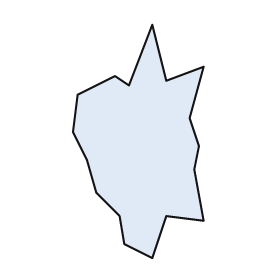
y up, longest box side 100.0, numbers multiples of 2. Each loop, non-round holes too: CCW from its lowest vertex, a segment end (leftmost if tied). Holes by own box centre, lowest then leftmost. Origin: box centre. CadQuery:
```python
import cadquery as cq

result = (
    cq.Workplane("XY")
    .moveTo(6.0, -50.0)
    .lineTo(12.0, -32.0)
    .lineTo(28.0, -34.0)
    .lineTo(24.0, -12.0)
    .lineTo(26.0, -2.0)
    .lineTo(22.0, 10.0)
    .lineTo(28.0, 32.0)
    .lineTo(12.0, 26.0)
    .lineTo(6.0, 50.0)
    .lineTo(-4.0, 24.0)
    .lineTo(-10.0, 28.0)
    .lineTo(-26.0, 20.0)
    .lineTo(-28.0, 4.0)
    .lineTo(-22.0, -8.0)
    .lineTo(-18.0, -22.0)
    .lineTo(-8.0, -32.0)
    .lineTo(-6.0, -44.0)
    .close()
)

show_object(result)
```